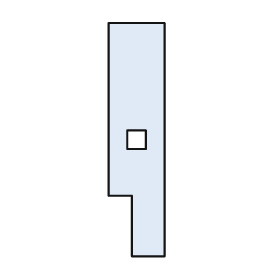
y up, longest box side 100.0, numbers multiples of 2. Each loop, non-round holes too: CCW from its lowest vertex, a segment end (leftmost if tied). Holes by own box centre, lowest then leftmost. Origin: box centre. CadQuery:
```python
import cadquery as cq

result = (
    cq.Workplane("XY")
    .moveTo(-2.0, -50.0)
    .lineTo(12.0, -50.0)
    .lineTo(12.0, 50.0)
    .lineTo(-12.0, 50.0)
    .lineTo(-12.0, -24.0)
    .lineTo(-2.0, -24.0)
    .close()
    .moveTo(-4.0, -4.0)
    .lineTo(4.0, -4.0)
    .lineTo(4.0, 4.0)
    .lineTo(-4.0, 4.0)
    .close()
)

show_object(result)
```